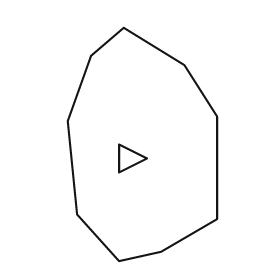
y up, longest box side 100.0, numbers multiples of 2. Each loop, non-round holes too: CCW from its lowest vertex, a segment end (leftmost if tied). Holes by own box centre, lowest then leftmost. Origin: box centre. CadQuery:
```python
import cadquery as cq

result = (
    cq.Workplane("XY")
    .moveTo(-10.0, -50.0)
    .lineTo(8.0, -46.0)
    .lineTo(32.0, -32.0)
    .lineTo(32.0, 12.0)
    .lineTo(18.0, 34.0)
    .lineTo(-8.0, 50.0)
    .lineTo(-22.0, 38.0)
    .lineTo(-32.0, 10.0)
    .lineTo(-28.0, -30.0)
    .close()
    .moveTo(-10.0, -12.0)
    .lineTo(2.0, -6.0)
    .lineTo(-10.0, 0.0)
    .close()
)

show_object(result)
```